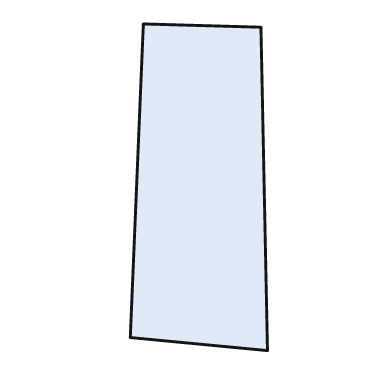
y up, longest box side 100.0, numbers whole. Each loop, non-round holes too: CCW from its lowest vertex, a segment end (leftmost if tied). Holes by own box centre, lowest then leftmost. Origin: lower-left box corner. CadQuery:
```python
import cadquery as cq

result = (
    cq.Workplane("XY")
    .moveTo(42.0, 0.0)
    .lineTo(40.0, 99.0)
    .lineTo(4.0, 100.0)
    .lineTo(0.0, 4.0)
    .close()
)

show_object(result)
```